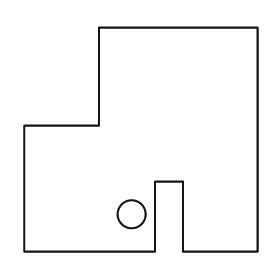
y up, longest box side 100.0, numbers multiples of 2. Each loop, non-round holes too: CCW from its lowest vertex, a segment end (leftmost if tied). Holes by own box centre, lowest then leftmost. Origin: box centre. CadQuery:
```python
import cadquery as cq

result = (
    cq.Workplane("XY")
    .moveTo(-50.0, -48.0)
    .lineTo(6.0, -48.0)
    .lineTo(6.0, -18.0)
    .lineTo(18.0, -18.0)
    .lineTo(18.0, -48.0)
    .lineTo(50.0, -48.0)
    .lineTo(50.0, 48.0)
    .lineTo(-18.0, 48.0)
    .lineTo(-18.0, 6.0)
    .lineTo(-50.0, 6.0)
    .close()
    .moveTo(-4.0, -32.0)
    .circle(6.0)
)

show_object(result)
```